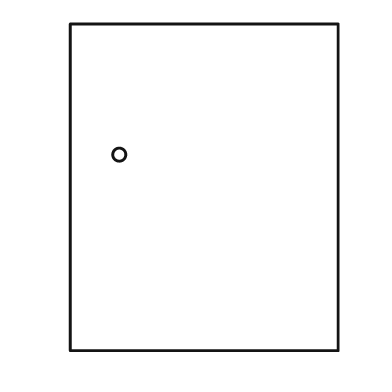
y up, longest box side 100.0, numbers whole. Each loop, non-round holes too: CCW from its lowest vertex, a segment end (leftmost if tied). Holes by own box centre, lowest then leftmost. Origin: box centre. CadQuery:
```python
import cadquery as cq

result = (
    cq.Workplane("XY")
    .moveTo(-41.0, -50.0)
    .lineTo(41.0, -50.0)
    .lineTo(41.0, 50.0)
    .lineTo(-41.0, 50.0)
    .close()
    .moveTo(-26.0, 10.0)
    .circle(2.0)
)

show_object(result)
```